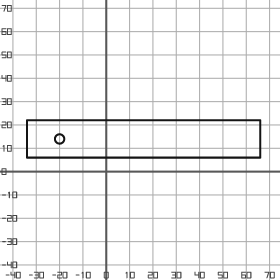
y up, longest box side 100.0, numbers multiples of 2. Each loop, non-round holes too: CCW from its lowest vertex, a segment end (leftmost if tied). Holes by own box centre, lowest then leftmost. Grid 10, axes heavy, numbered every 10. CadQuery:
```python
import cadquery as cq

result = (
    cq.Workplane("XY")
    .moveTo(-34.0, 6.0)
    .lineTo(66.0, 6.0)
    .lineTo(66.0, 22.0)
    .lineTo(-34.0, 22.0)
    .close()
    .moveTo(-20.0, 14.0)
    .circle(2.0)
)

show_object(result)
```